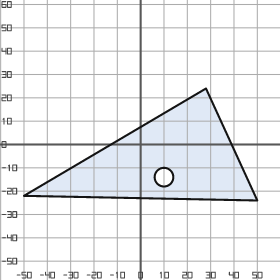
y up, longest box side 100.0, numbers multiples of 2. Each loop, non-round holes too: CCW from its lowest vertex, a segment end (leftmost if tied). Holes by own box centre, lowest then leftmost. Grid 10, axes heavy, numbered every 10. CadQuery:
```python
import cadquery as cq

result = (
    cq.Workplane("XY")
    .moveTo(50.0, -24.0)
    .lineTo(28.0, 24.0)
    .lineTo(-50.0, -22.0)
    .close()
    .moveTo(10.0, -14.0)
    .circle(4.0)
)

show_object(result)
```